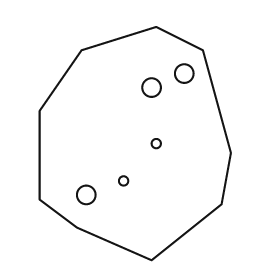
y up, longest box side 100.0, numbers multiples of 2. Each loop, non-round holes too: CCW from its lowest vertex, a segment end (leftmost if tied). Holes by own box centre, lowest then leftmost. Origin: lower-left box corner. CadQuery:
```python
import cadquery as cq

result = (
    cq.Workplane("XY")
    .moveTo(48.0, 0.0)
    .lineTo(78.0, 24.0)
    .lineTo(82.0, 46.0)
    .lineTo(70.0, 90.0)
    .lineTo(50.0, 100.0)
    .lineTo(18.0, 90.0)
    .lineTo(0.0, 64.0)
    .lineTo(0.0, 26.0)
    .lineTo(16.0, 14.0)
    .close()
    .moveTo(20.0, 28.0)
    .circle(4.0)
    .moveTo(36.0, 34.0)
    .circle(2.0)
    .moveTo(50.0, 50.0)
    .circle(2.0)
    .moveTo(48.0, 74.0)
    .circle(4.0)
    .moveTo(62.0, 80.0)
    .circle(4.0)
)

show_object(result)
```